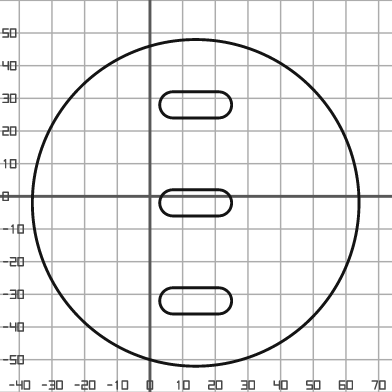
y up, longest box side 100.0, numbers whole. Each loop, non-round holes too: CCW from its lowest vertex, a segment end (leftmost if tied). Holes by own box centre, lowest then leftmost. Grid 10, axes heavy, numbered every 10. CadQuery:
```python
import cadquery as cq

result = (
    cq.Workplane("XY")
    .moveTo(14.0, -2.0)
    .circle(50.0)
    .moveTo(7.0, -36.0)
    .lineTo(21.0, -36.0)
    .threePointArc((25.0, -32.0), (21.0, -28.0))
    .lineTo(7.0, -28.0)
    .threePointArc((3.0, -32.0), (7.0, -36.0))
    .close()
    .moveTo(7.0, -6.0)
    .lineTo(21.0, -6.0)
    .threePointArc((25.0, -2.0), (21.0, 2.0))
    .lineTo(7.0, 2.0)
    .threePointArc((3.0, -2.0), (7.0, -6.0))
    .close()
    .moveTo(7.0, 24.0)
    .lineTo(21.0, 24.0)
    .threePointArc((25.0, 28.0), (21.0, 32.0))
    .lineTo(7.0, 32.0)
    .threePointArc((3.0, 28.0), (7.0, 24.0))
    .close()
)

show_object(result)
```